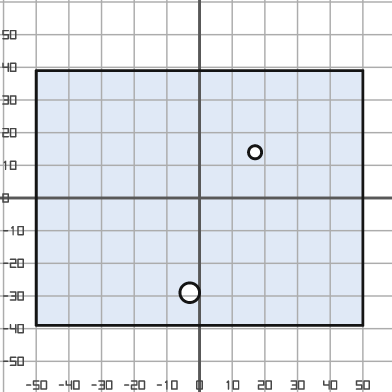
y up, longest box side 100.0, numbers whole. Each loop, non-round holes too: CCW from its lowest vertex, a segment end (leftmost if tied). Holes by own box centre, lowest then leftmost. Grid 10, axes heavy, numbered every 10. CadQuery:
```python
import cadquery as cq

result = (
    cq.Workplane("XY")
    .moveTo(-50.0, -39.0)
    .lineTo(50.0, -39.0)
    .lineTo(50.0, 39.0)
    .lineTo(-50.0, 39.0)
    .close()
    .moveTo(-3.0, -29.0)
    .circle(3.0)
    .moveTo(17.0, 14.0)
    .circle(2.0)
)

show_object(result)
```